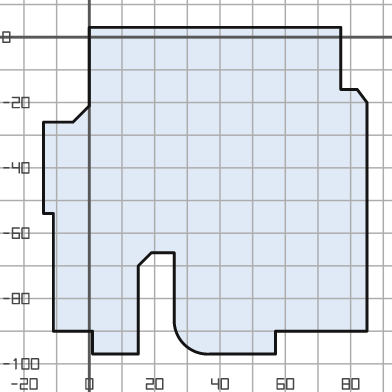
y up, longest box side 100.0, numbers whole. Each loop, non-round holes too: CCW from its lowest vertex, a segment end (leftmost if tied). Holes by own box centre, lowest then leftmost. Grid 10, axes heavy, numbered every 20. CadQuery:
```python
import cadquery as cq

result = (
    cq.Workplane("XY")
    .moveTo(1.0, -97.0)
    .lineTo(15.0, -97.0)
    .lineTo(15.0, -70.0)
    .lineTo(19.0, -66.0)
    .lineTo(26.0, -66.0)
    .lineTo(26.0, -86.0)
    .threePointArc((29.0, -94.0), (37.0, -97.0))
    .lineTo(57.0, -97.0)
    .lineTo(57.0, -90.0)
    .lineTo(85.0, -90.0)
    .lineTo(85.0, -20.0)
    .lineTo(82.0, -16.0)
    .lineTo(77.0, -16.0)
    .lineTo(77.0, 3.0)
    .lineTo(0.0, 3.0)
    .lineTo(0.0, -21.0)
    .lineTo(-5.0, -26.0)
    .lineTo(-14.0, -26.0)
    .lineTo(-14.0, -54.0)
    .lineTo(-11.0, -54.0)
    .lineTo(-11.0, -90.0)
    .lineTo(1.0, -90.0)
    .close()
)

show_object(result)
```